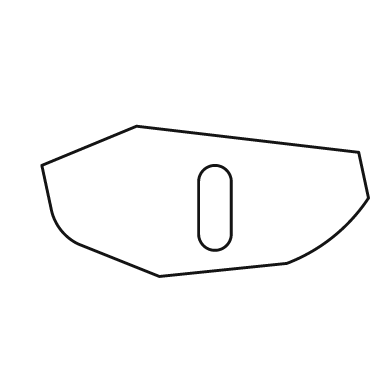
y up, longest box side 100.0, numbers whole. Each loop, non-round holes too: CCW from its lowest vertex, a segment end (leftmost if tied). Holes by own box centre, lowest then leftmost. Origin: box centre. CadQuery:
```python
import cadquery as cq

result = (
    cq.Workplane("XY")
    .moveTo(-14.0, -23.0)
    .lineTo(25.0, -19.0)
    .threePointArc((39.0, -11.0), (50.0, 1.0))
    .lineTo(47.0, 15.0)
    .lineTo(-21.0, 23.0)
    .lineTo(-50.0, 11.0)
    .lineTo(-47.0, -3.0)
    .threePointArc((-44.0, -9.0), (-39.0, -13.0))
    .close()
    .moveTo(-2.0, -10.0)
    .threePointArc((3.0, -15.0), (8.0, -10.0))
    .lineTo(8.0, 6.0)
    .threePointArc((3.0, 11.0), (-2.0, 6.0))
    .close()
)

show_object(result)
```